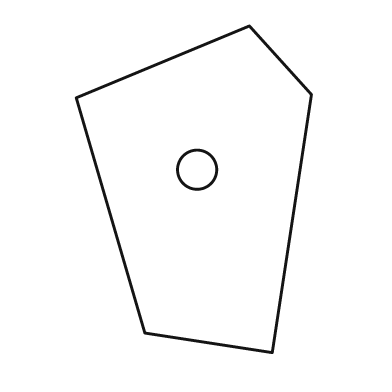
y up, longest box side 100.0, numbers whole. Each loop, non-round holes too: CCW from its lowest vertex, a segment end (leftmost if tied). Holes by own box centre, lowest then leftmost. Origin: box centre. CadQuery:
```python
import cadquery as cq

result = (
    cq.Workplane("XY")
    .moveTo(24.0, -50.0)
    .lineTo(36.0, 29.0)
    .lineTo(17.0, 50.0)
    .lineTo(-36.0, 28.0)
    .lineTo(-15.0, -44.0)
    .close()
    .moveTo(1.0, 6.0)
    .circle(6.0)
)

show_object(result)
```